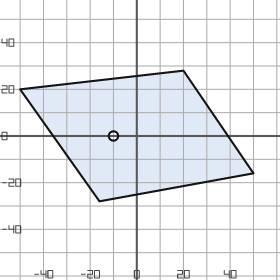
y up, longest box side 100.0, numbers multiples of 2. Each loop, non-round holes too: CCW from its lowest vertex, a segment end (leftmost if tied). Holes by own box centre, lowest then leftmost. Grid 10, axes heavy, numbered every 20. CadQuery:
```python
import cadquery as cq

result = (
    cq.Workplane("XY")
    .moveTo(-16.0, -28.0)
    .lineTo(50.0, -16.0)
    .lineTo(20.0, 28.0)
    .lineTo(-50.0, 20.0)
    .close()
    .moveTo(-10.0, 0.0)
    .circle(2.0)
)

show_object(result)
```